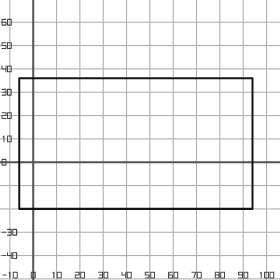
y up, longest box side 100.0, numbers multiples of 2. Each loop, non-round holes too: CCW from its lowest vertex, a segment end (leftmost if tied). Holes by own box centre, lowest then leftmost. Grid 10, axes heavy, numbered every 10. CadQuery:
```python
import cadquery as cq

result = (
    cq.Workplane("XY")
    .moveTo(-6.0, -20.0)
    .lineTo(94.0, -20.0)
    .lineTo(94.0, 36.0)
    .lineTo(-6.0, 36.0)
    .close()
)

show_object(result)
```